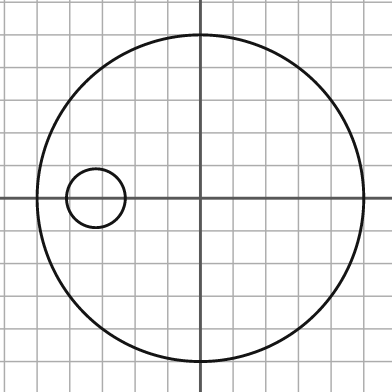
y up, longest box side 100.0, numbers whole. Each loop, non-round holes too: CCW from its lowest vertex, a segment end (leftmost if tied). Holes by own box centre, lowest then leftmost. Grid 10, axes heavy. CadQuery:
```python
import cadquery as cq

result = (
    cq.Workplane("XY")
    .moveTo(0.0, 0.0)
    .circle(50.0)
    .moveTo(-32.0, 0.0)
    .circle(9.0)
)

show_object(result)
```